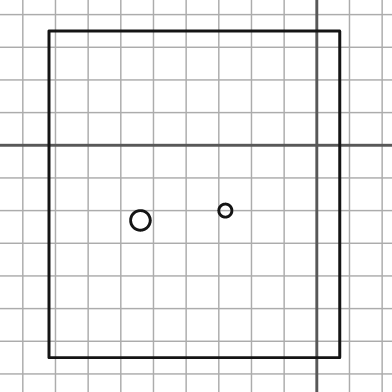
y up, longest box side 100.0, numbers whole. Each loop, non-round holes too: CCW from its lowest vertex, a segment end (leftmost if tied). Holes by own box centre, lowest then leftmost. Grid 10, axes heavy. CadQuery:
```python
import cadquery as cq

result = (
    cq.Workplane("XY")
    .moveTo(-82.0, -65.0)
    .lineTo(7.0, -65.0)
    .lineTo(7.0, 35.0)
    .lineTo(-82.0, 35.0)
    .close()
    .moveTo(-54.0, -23.0)
    .circle(3.0)
    .moveTo(-28.0, -20.0)
    .circle(2.0)
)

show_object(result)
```